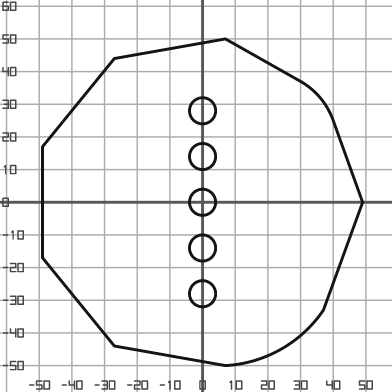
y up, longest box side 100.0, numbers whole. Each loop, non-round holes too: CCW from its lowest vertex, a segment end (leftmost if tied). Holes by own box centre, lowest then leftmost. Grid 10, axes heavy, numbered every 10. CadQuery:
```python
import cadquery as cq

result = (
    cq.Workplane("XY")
    .moveTo(7.0, -50.0)
    .threePointArc((24.0, -45.0), (37.0, -33.0))
    .lineTo(49.0, 0.0)
    .lineTo(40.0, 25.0)
    .threePointArc((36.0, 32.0), (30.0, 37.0))
    .lineTo(7.0, 50.0)
    .lineTo(-27.0, 44.0)
    .lineTo(-49.0, 17.0)
    .lineTo(-49.0, -17.0)
    .lineTo(-27.0, -44.0)
    .close()
    .moveTo(0.0, -28.0)
    .circle(4.0)
    .moveTo(0.0, -14.0)
    .circle(4.0)
    .moveTo(0.0, 0.0)
    .circle(4.0)
    .moveTo(0.0, 14.0)
    .circle(4.0)
    .moveTo(0.0, 28.0)
    .circle(4.0)
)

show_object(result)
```